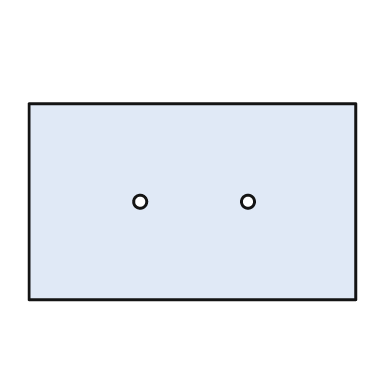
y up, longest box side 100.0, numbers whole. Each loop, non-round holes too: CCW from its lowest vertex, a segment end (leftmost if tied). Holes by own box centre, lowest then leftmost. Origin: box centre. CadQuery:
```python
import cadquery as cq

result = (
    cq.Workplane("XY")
    .moveTo(-50.0, -30.0)
    .lineTo(50.0, -30.0)
    .lineTo(50.0, 30.0)
    .lineTo(-50.0, 30.0)
    .close()
    .moveTo(-16.0, 0.0)
    .circle(2.0)
    .moveTo(17.0, 0.0)
    .circle(2.0)
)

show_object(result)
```